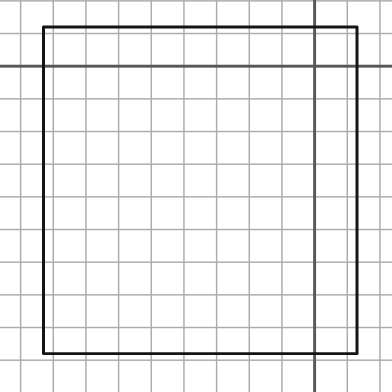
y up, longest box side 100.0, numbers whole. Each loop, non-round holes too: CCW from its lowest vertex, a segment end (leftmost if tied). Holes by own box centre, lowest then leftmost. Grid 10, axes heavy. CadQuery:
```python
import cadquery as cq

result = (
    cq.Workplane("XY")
    .moveTo(-83.0, -88.0)
    .lineTo(13.0, -88.0)
    .lineTo(13.0, 12.0)
    .lineTo(-83.0, 12.0)
    .close()
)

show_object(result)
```